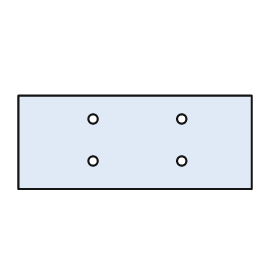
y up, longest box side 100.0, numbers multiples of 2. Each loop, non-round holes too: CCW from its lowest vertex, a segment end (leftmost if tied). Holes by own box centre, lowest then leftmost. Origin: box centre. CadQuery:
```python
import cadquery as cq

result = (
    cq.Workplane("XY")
    .moveTo(-50.0, -20.0)
    .lineTo(50.0, -20.0)
    .lineTo(50.0, 20.0)
    .lineTo(-50.0, 20.0)
    .close()
    .moveTo(-18.0, -8.0)
    .circle(2.0)
    .moveTo(20.0, -8.0)
    .circle(2.0)
    .moveTo(-18.0, 10.0)
    .circle(2.0)
    .moveTo(20.0, 10.0)
    .circle(2.0)
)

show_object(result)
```